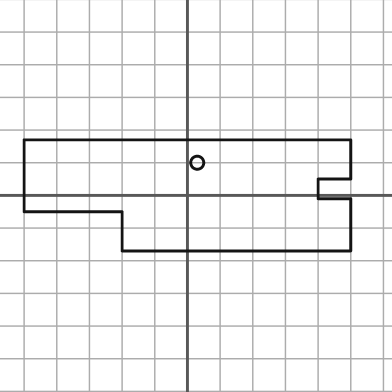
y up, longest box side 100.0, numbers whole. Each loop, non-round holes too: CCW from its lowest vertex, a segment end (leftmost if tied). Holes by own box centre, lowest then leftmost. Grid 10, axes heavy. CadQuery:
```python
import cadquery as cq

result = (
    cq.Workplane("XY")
    .moveTo(-20.0, -17.0)
    .lineTo(50.0, -17.0)
    .lineTo(50.0, -1.0)
    .lineTo(40.0, -1.0)
    .lineTo(40.0, 5.0)
    .lineTo(50.0, 5.0)
    .lineTo(50.0, 17.0)
    .lineTo(-50.0, 17.0)
    .lineTo(-50.0, -5.0)
    .lineTo(-20.0, -5.0)
    .close()
    .moveTo(3.0, 10.0)
    .circle(2.0)
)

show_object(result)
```